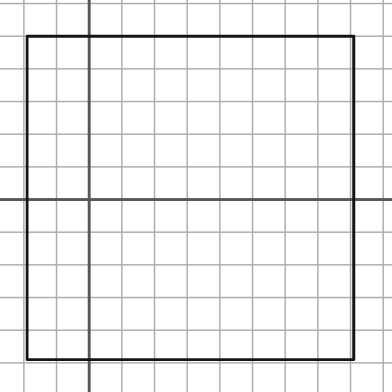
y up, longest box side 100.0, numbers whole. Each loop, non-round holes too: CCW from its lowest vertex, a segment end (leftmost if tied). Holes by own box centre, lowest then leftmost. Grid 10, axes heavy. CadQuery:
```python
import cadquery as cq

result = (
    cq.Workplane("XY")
    .moveTo(-19.0, -49.0)
    .lineTo(81.0, -49.0)
    .lineTo(81.0, 50.0)
    .lineTo(-19.0, 50.0)
    .close()
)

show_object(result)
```